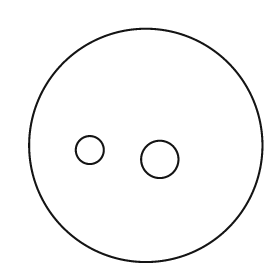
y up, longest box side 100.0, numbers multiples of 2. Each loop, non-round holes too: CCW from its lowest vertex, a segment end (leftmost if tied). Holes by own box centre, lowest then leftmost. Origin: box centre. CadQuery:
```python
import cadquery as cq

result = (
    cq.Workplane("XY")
    .moveTo(0.0, 0.0)
    .circle(50.0)
    .moveTo(6.0, -6.0)
    .circle(8.0)
    .moveTo(-24.0, -2.0)
    .circle(6.0)
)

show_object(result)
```